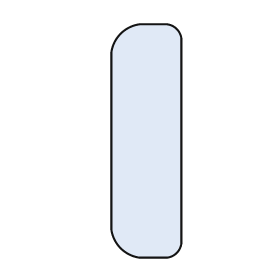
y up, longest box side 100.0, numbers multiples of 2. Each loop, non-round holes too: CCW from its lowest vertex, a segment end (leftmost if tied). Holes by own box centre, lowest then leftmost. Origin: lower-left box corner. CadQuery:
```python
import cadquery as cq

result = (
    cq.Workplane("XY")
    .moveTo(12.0, 0.0)
    .lineTo(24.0, 0.0)
    .threePointArc((28.0, 2.0), (30.0, 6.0))
    .lineTo(30.0, 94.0)
    .threePointArc((28.0, 98.0), (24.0, 100.0))
    .lineTo(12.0, 100.0)
    .threePointArc((4.0, 96.0), (0.0, 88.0))
    .lineTo(0.0, 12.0)
    .threePointArc((4.0, 4.0), (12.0, 0.0))
    .close()
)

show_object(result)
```